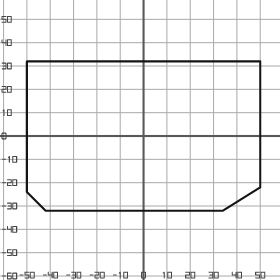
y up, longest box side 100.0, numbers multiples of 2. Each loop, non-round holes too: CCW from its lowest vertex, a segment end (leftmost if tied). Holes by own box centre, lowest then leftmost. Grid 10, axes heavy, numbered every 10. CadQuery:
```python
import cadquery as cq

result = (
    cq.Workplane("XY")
    .moveTo(-42.0, -32.0)
    .lineTo(34.0, -32.0)
    .lineTo(50.0, -22.0)
    .lineTo(50.0, 32.0)
    .lineTo(-50.0, 32.0)
    .lineTo(-50.0, -24.0)
    .close()
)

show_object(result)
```